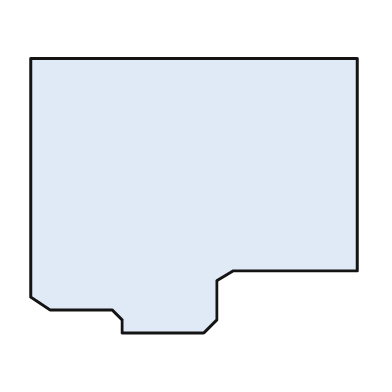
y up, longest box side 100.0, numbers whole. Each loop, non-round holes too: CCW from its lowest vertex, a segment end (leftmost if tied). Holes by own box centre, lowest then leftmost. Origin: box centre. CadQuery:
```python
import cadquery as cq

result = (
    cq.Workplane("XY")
    .moveTo(-22.0, -42.0)
    .lineTo(3.0, -42.0)
    .lineTo(7.0, -38.0)
    .lineTo(7.0, -26.0)
    .lineTo(12.0, -23.0)
    .lineTo(50.0, -23.0)
    .lineTo(50.0, 42.0)
    .lineTo(-50.0, 42.0)
    .lineTo(-50.0, -31.0)
    .lineTo(-44.0, -35.0)
    .lineTo(-25.0, -35.0)
    .lineTo(-22.0, -38.0)
    .close()
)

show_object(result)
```